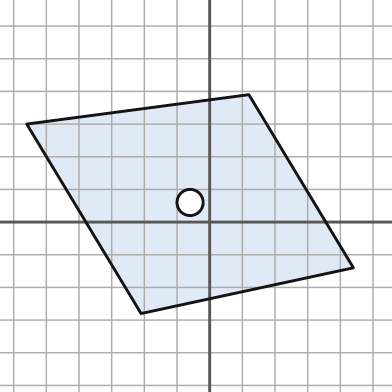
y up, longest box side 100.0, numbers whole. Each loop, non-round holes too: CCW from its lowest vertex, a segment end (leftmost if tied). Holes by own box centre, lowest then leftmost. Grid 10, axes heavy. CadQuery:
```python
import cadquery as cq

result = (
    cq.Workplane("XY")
    .moveTo(-21.0, -28.0)
    .lineTo(44.0, -14.0)
    .lineTo(12.0, 39.0)
    .lineTo(-56.0, 30.0)
    .close()
    .moveTo(-6.0, 6.0)
    .circle(4.0)
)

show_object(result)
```